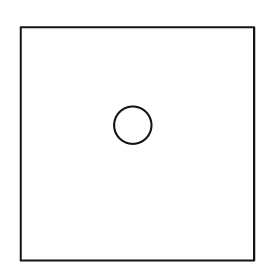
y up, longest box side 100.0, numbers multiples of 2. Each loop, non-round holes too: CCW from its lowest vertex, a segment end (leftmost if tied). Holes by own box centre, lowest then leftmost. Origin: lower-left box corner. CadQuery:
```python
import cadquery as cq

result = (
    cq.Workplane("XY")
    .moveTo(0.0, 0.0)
    .lineTo(100.0, 0.0)
    .lineTo(100.0, 100.0)
    .lineTo(0.0, 100.0)
    .close()
    .moveTo(48.0, 58.0)
    .circle(8.0)
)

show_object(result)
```